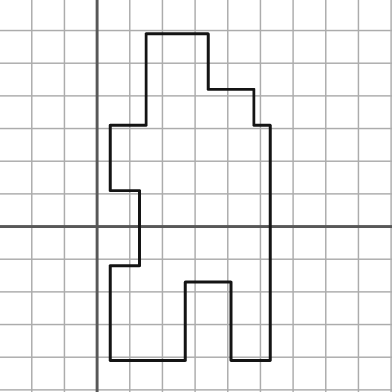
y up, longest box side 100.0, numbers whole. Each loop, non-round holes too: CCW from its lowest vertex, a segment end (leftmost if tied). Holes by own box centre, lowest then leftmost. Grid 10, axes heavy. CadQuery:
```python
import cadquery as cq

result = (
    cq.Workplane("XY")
    .moveTo(4.0, -41.0)
    .lineTo(27.0, -41.0)
    .lineTo(27.0, -17.0)
    .lineTo(41.0, -17.0)
    .lineTo(41.0, -41.0)
    .lineTo(53.0, -41.0)
    .lineTo(53.0, 31.0)
    .lineTo(48.0, 31.0)
    .lineTo(48.0, 42.0)
    .lineTo(34.0, 42.0)
    .lineTo(34.0, 59.0)
    .lineTo(15.0, 59.0)
    .lineTo(15.0, 31.0)
    .lineTo(4.0, 31.0)
    .lineTo(4.0, 11.0)
    .lineTo(13.0, 11.0)
    .lineTo(13.0, -12.0)
    .lineTo(4.0, -12.0)
    .close()
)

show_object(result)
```